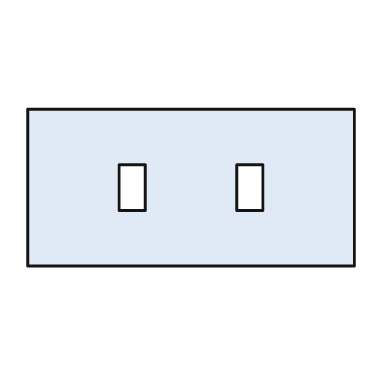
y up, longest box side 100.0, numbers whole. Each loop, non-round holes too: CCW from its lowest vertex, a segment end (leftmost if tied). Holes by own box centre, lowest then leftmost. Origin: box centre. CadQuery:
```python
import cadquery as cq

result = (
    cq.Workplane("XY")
    .moveTo(-50.0, -24.0)
    .lineTo(50.0, -24.0)
    .lineTo(50.0, 24.0)
    .lineTo(-50.0, 24.0)
    .close()
    .moveTo(-22.0, -7.0)
    .lineTo(-14.0, -7.0)
    .lineTo(-14.0, 7.0)
    .lineTo(-22.0, 7.0)
    .close()
    .moveTo(14.0, -7.0)
    .lineTo(22.0, -7.0)
    .lineTo(22.0, 7.0)
    .lineTo(14.0, 7.0)
    .close()
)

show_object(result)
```